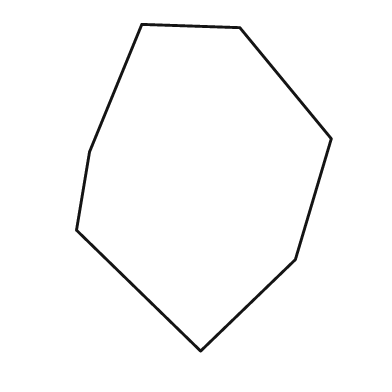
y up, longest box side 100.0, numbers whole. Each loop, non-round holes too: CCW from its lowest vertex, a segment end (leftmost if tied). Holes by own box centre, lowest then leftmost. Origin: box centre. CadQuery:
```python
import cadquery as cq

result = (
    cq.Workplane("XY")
    .moveTo(-1.0, -50.0)
    .lineTo(28.0, -22.0)
    .lineTo(39.0, 15.0)
    .lineTo(11.0, 49.0)
    .lineTo(-19.0, 50.0)
    .lineTo(-35.0, 11.0)
    .lineTo(-39.0, -13.0)
    .close()
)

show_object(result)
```